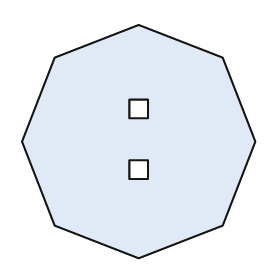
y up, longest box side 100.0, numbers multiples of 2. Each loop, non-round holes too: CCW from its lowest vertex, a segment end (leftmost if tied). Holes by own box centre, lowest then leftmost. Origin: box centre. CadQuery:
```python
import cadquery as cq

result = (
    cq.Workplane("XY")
    .moveTo(0.0, -50.0)
    .lineTo(36.0, -36.0)
    .lineTo(50.0, 0.0)
    .lineTo(36.0, 36.0)
    .lineTo(0.0, 50.0)
    .lineTo(-36.0, 36.0)
    .lineTo(-50.0, 0.0)
    .lineTo(-36.0, -36.0)
    .close()
    .moveTo(-4.0, -16.0)
    .lineTo(4.0, -16.0)
    .lineTo(4.0, -8.0)
    .lineTo(-4.0, -8.0)
    .close()
    .moveTo(-4.0, 10.0)
    .lineTo(4.0, 10.0)
    .lineTo(4.0, 18.0)
    .lineTo(-4.0, 18.0)
    .close()
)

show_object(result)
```